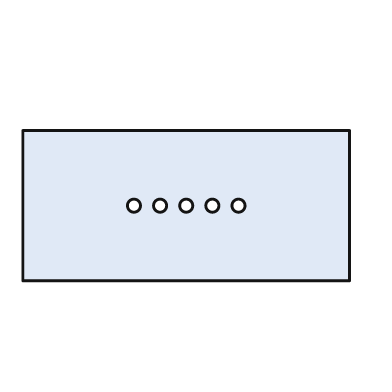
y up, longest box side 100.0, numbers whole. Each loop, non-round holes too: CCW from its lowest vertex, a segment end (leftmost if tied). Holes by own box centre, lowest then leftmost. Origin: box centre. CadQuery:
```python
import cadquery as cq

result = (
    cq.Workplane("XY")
    .moveTo(-50.0, -23.0)
    .lineTo(50.0, -23.0)
    .lineTo(50.0, 23.0)
    .lineTo(-50.0, 23.0)
    .close()
    .moveTo(-16.0, 0.0)
    .circle(2.0)
    .moveTo(-8.0, 0.0)
    .circle(2.0)
    .moveTo(0.0, 0.0)
    .circle(2.0)
    .moveTo(8.0, 0.0)
    .circle(2.0)
    .moveTo(16.0, 0.0)
    .circle(2.0)
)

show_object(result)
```